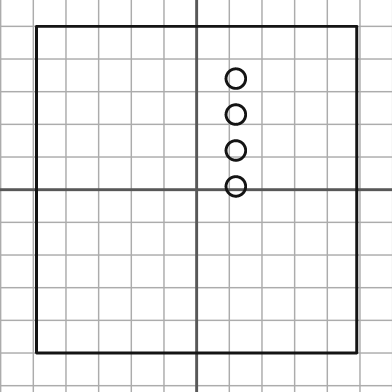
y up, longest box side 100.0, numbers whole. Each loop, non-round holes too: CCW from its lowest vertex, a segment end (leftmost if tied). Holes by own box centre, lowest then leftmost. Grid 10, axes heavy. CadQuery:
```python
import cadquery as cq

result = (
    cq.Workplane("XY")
    .moveTo(-49.0, -50.0)
    .lineTo(49.0, -50.0)
    .lineTo(49.0, 50.0)
    .lineTo(-49.0, 50.0)
    .close()
    .moveTo(12.0, 1.0)
    .circle(3.0)
    .moveTo(12.0, 12.0)
    .circle(3.0)
    .moveTo(12.0, 23.0)
    .circle(3.0)
    .moveTo(12.0, 34.0)
    .circle(3.0)
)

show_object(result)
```